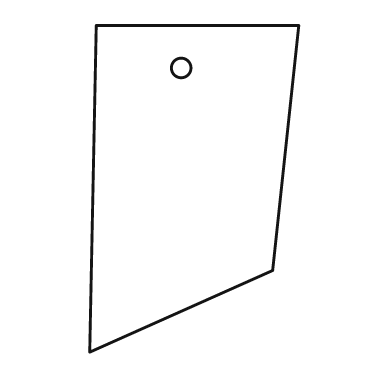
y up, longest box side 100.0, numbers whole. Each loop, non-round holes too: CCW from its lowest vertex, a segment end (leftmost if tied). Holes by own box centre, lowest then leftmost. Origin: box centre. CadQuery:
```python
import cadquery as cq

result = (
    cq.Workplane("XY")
    .moveTo(-32.0, -50.0)
    .lineTo(24.0, -25.0)
    .lineTo(32.0, 50.0)
    .lineTo(-30.0, 50.0)
    .close()
    .moveTo(-4.0, 37.0)
    .circle(3.0)
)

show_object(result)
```